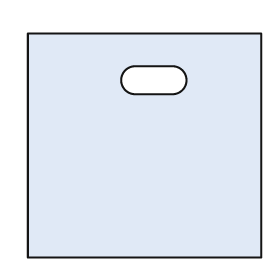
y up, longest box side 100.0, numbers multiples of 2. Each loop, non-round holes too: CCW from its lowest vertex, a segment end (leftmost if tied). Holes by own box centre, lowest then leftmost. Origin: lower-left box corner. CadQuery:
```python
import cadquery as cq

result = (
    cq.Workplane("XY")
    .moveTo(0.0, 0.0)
    .lineTo(100.0, 0.0)
    .lineTo(100.0, 96.0)
    .lineTo(0.0, 96.0)
    .close()
    .moveTo(46.0, 70.0)
    .lineTo(62.0, 70.0)
    .threePointArc((68.0, 76.0), (62.0, 82.0))
    .lineTo(46.0, 82.0)
    .threePointArc((40.0, 76.0), (46.0, 70.0))
    .close()
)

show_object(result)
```